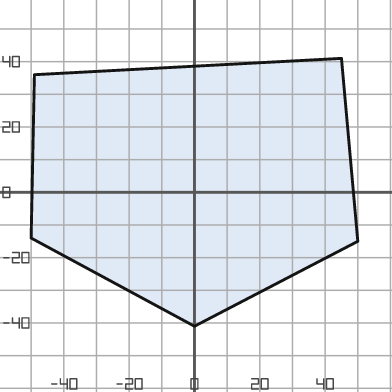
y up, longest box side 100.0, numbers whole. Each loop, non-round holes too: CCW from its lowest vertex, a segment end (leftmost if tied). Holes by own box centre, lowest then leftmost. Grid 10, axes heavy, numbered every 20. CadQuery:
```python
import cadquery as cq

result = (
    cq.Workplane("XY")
    .moveTo(0.0, -41.0)
    .lineTo(50.0, -15.0)
    .lineTo(45.0, 41.0)
    .lineTo(-49.0, 36.0)
    .lineTo(-50.0, -14.0)
    .close()
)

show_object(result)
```